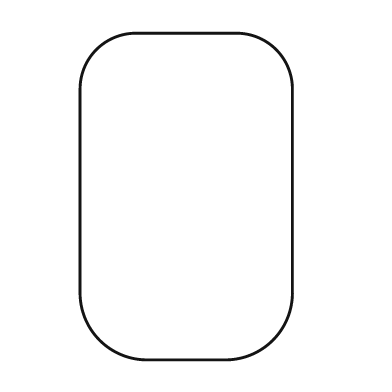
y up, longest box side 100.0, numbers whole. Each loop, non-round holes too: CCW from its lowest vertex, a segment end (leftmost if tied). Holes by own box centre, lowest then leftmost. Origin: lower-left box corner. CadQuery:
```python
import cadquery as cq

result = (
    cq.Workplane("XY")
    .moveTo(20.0, 0.0)
    .lineTo(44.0, 0.0)
    .threePointArc((59.0, 6.0), (65.0, 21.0))
    .lineTo(65.0, 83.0)
    .threePointArc((60.0, 95.0), (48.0, 100.0))
    .lineTo(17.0, 100.0)
    .threePointArc((5.0, 95.0), (0.0, 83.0))
    .lineTo(0.0, 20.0)
    .threePointArc((6.0, 6.0), (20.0, 0.0))
    .close()
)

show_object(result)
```